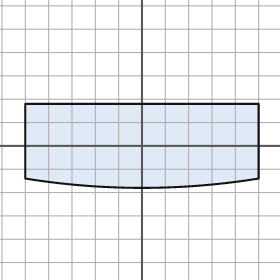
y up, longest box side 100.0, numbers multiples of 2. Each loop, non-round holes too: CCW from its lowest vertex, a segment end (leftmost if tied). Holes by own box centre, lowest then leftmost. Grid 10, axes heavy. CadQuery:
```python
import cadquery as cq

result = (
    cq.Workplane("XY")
    .moveTo(-50.0, -14.0)
    .threePointArc((0.0, -18.0), (50.0, -14.0))
    .lineTo(50.0, 18.0)
    .lineTo(-50.0, 18.0)
    .close()
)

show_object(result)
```